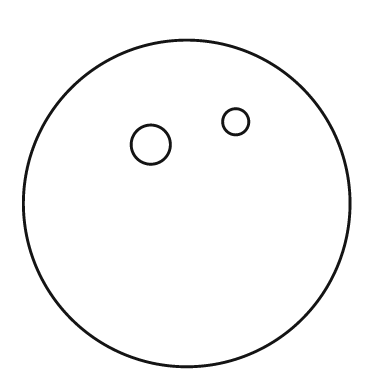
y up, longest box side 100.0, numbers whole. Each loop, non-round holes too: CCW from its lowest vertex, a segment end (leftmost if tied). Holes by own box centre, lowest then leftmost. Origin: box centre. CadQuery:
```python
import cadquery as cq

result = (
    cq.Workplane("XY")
    .moveTo(0.0, 0.0)
    .circle(50.0)
    .moveTo(-11.0, 18.0)
    .circle(6.0)
    .moveTo(15.0, 25.0)
    .circle(4.0)
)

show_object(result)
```